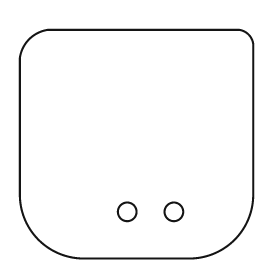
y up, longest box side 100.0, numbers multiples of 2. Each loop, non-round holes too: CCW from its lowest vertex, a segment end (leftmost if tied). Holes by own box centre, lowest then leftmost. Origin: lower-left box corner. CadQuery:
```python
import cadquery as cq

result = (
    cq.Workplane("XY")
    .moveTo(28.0, 0.0)
    .lineTo(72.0, 0.0)
    .threePointArc((92.0, 8.0), (100.0, 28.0))
    .lineTo(100.0, 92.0)
    .threePointArc((98.0, 96.0), (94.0, 98.0))
    .lineTo(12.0, 98.0)
    .threePointArc((4.0, 94.0), (0.0, 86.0))
    .lineTo(0.0, 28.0)
    .threePointArc((8.0, 8.0), (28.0, 0.0))
    .close()
    .moveTo(46.0, 20.0)
    .circle(4.0)
    .moveTo(66.0, 20.0)
    .circle(4.0)
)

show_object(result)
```